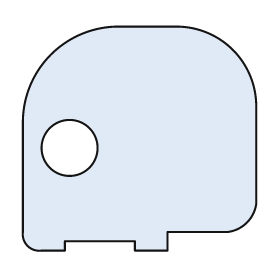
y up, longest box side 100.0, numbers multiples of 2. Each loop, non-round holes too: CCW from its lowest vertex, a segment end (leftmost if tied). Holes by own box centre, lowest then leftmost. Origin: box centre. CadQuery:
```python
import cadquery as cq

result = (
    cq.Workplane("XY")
    .moveTo(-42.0, -48.0)
    .lineTo(-32.0, -48.0)
    .lineTo(-32.0, -44.0)
    .lineTo(-2.0, -44.0)
    .lineTo(-2.0, -48.0)
    .lineTo(12.0, -48.0)
    .lineTo(12.0, -40.0)
    .lineTo(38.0, -40.0)
    .threePointArc((46.0, -36.0), (50.0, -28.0))
    .lineTo(50.0, 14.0)
    .threePointArc((40.0, 38.0), (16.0, 48.0))
    .lineTo(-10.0, 48.0)
    .threePointArc((-38.0, 36.0), (-50.0, 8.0))
    .lineTo(-50.0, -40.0)
    .threePointArc((-48.0, -46.0), (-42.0, -48.0))
    .close()
    .moveTo(-30.0, -4.0)
    .circle(12.0)
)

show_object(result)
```